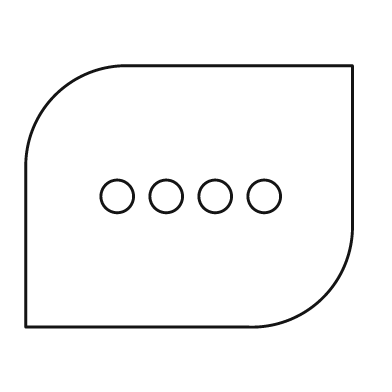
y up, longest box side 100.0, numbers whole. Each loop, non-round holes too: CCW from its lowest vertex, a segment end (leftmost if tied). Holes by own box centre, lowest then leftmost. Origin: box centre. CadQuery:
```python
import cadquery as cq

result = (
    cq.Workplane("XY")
    .moveTo(-50.0, -40.0)
    .lineTo(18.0, -40.0)
    .threePointArc((41.0, -31.0), (50.0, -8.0))
    .lineTo(50.0, 40.0)
    .lineTo(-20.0, 40.0)
    .threePointArc((-41.0, 31.0), (-50.0, 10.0))
    .close()
    .moveTo(-22.0, 0.0)
    .circle(5.0)
    .moveTo(-7.0, 0.0)
    .circle(5.0)
    .moveTo(8.0, 0.0)
    .circle(5.0)
    .moveTo(23.0, 0.0)
    .circle(5.0)
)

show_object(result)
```